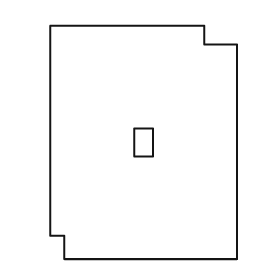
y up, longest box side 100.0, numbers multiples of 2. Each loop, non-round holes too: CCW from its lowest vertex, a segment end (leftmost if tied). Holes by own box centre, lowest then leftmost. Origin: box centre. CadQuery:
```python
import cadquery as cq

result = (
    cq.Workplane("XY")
    .moveTo(-34.0, -50.0)
    .lineTo(40.0, -50.0)
    .lineTo(40.0, 42.0)
    .lineTo(26.0, 42.0)
    .lineTo(26.0, 50.0)
    .lineTo(-40.0, 50.0)
    .lineTo(-40.0, -40.0)
    .lineTo(-34.0, -40.0)
    .close()
    .moveTo(-4.0, -6.0)
    .lineTo(4.0, -6.0)
    .lineTo(4.0, 6.0)
    .lineTo(-4.0, 6.0)
    .close()
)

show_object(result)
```